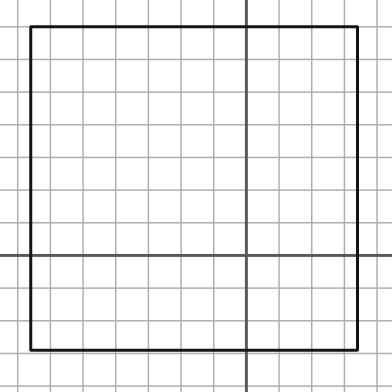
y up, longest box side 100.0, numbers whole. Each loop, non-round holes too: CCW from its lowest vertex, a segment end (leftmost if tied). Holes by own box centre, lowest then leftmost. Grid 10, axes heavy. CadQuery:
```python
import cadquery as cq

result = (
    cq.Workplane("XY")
    .moveTo(-66.0, -29.0)
    .lineTo(34.0, -29.0)
    .lineTo(34.0, 70.0)
    .lineTo(-66.0, 70.0)
    .close()
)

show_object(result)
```